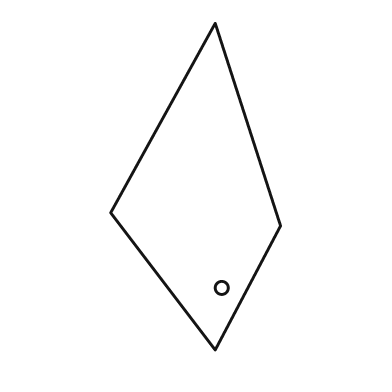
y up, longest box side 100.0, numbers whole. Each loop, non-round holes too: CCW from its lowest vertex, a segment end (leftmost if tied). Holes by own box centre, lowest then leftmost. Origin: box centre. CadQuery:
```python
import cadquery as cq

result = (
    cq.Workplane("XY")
    .moveTo(6.0, -50.0)
    .lineTo(26.0, -12.0)
    .lineTo(6.0, 50.0)
    .lineTo(-26.0, -8.0)
    .close()
    .moveTo(8.0, -31.0)
    .circle(2.0)
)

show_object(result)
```